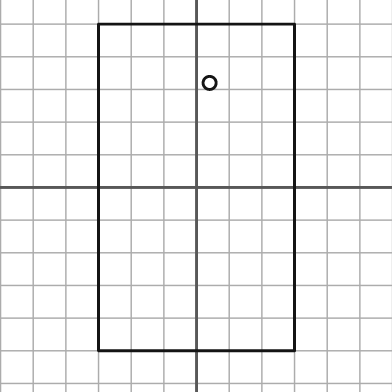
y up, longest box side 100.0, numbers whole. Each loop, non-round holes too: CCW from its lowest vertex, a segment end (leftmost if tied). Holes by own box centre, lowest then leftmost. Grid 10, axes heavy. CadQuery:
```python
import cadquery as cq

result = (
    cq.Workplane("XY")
    .moveTo(-30.0, -50.0)
    .lineTo(30.0, -50.0)
    .lineTo(30.0, 50.0)
    .lineTo(-30.0, 50.0)
    .close()
    .moveTo(4.0, 32.0)
    .circle(2.0)
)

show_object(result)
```